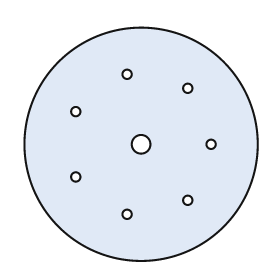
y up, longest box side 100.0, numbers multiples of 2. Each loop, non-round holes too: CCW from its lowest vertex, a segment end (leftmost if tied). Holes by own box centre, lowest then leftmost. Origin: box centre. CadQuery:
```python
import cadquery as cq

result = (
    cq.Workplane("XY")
    .moveTo(0.0, 0.0)
    .circle(50.0)
    .moveTo(-6.0, -30.0)
    .circle(2.0)
    .moveTo(20.0, -24.0)
    .circle(2.0)
    .moveTo(-28.0, -14.0)
    .circle(2.0)
    .moveTo(0.0, 0.0)
    .circle(4.0)
    .moveTo(30.0, 0.0)
    .circle(2.0)
    .moveTo(-28.0, 14.0)
    .circle(2.0)
    .moveTo(20.0, 24.0)
    .circle(2.0)
    .moveTo(-6.0, 30.0)
    .circle(2.0)
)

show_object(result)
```